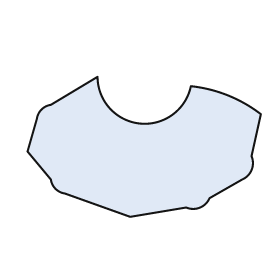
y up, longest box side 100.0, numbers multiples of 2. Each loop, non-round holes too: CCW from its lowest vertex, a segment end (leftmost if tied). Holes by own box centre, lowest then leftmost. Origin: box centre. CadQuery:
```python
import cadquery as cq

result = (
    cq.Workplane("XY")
    .moveTo(-6.0, -30.0)
    .lineTo(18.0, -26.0)
    .threePointArc((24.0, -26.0), (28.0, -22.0))
    .lineTo(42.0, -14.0)
    .threePointArc((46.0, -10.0), (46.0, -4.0))
    .lineTo(50.0, 14.0)
    .threePointArc((36.0, 22.0), (20.0, 26.0))
    .threePointArc((-2.0, 10.0), (-20.0, 30.0))
    .lineTo(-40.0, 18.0)
    .threePointArc((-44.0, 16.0), (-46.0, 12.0))
    .lineTo(-50.0, -2.0)
    .lineTo(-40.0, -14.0)
    .threePointArc((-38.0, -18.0), (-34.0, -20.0))
    .close()
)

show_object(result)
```